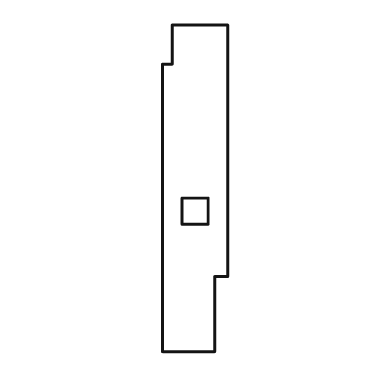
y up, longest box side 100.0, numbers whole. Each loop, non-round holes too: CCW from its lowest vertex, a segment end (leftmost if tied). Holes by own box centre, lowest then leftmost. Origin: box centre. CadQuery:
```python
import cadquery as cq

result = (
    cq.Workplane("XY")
    .moveTo(-10.0, -50.0)
    .lineTo(6.0, -50.0)
    .lineTo(6.0, -27.0)
    .lineTo(10.0, -27.0)
    .lineTo(10.0, 50.0)
    .lineTo(-7.0, 50.0)
    .lineTo(-7.0, 38.0)
    .lineTo(-10.0, 38.0)
    .close()
    .moveTo(-4.0, -11.0)
    .lineTo(4.0, -11.0)
    .lineTo(4.0, -3.0)
    .lineTo(-4.0, -3.0)
    .close()
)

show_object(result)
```